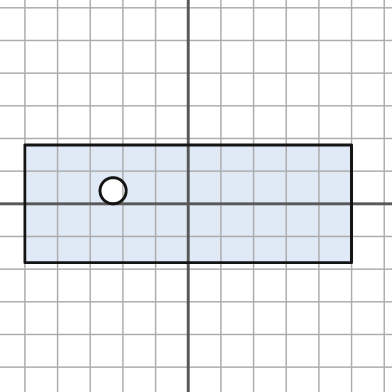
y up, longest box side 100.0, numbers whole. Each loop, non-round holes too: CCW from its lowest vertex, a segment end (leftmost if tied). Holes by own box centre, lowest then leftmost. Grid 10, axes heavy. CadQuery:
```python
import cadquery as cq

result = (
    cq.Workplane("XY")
    .moveTo(-50.0, -18.0)
    .lineTo(50.0, -18.0)
    .lineTo(50.0, 18.0)
    .lineTo(-50.0, 18.0)
    .close()
    .moveTo(-23.0, 4.0)
    .circle(4.0)
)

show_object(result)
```